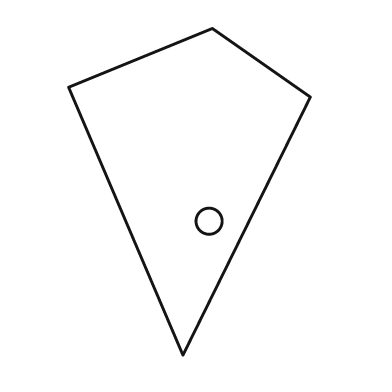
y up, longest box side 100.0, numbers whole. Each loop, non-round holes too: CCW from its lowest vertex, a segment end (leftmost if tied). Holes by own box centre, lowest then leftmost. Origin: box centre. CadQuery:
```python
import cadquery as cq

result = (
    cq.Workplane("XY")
    .moveTo(-2.0, -50.0)
    .lineTo(37.0, 29.0)
    .lineTo(7.0, 50.0)
    .lineTo(-37.0, 32.0)
    .close()
    .moveTo(6.0, -9.0)
    .circle(4.0)
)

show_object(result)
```